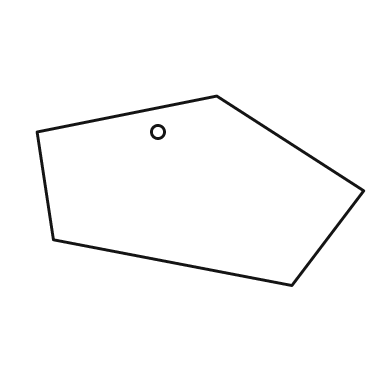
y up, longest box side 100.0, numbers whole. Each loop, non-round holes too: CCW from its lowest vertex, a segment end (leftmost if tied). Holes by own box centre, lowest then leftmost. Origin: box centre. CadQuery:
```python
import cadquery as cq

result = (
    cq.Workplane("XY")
    .moveTo(28.0, -29.0)
    .lineTo(50.0, 0.0)
    .lineTo(5.0, 29.0)
    .lineTo(-50.0, 18.0)
    .lineTo(-45.0, -15.0)
    .close()
    .moveTo(-13.0, 18.0)
    .circle(2.0)
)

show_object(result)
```